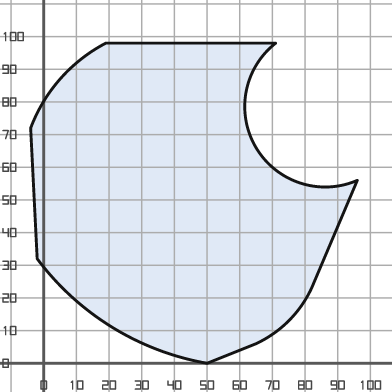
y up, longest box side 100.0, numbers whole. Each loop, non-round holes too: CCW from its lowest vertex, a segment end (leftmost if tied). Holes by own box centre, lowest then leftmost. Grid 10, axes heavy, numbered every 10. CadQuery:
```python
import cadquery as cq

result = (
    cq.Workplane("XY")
    .moveTo(50.0, 0.0)
    .lineTo(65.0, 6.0)
    .threePointArc((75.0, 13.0), (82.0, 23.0))
    .lineTo(96.0, 56.0)
    .threePointArc((65.0, 66.0), (71.0, 98.0))
    .lineTo(19.0, 98.0)
    .threePointArc((5.0, 87.0), (-4.0, 72.0))
    .lineTo(-2.0, 32.0)
    .threePointArc((21.0, 11.0), (50.0, 0.0))
    .close()
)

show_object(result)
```